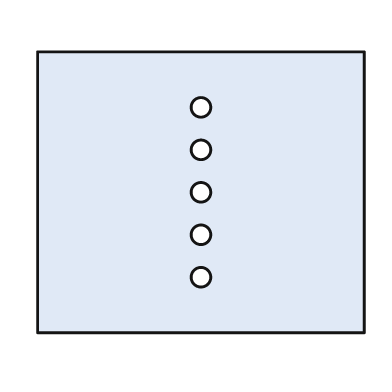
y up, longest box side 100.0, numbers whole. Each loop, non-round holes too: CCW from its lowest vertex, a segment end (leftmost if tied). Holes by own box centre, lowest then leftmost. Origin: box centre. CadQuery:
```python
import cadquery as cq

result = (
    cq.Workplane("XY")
    .moveTo(-50.0, -43.0)
    .lineTo(50.0, -43.0)
    .lineTo(50.0, 43.0)
    .lineTo(-50.0, 43.0)
    .close()
    .moveTo(0.0, -26.0)
    .circle(3.0)
    .moveTo(0.0, -13.0)
    .circle(3.0)
    .moveTo(0.0, 0.0)
    .circle(3.0)
    .moveTo(0.0, 13.0)
    .circle(3.0)
    .moveTo(0.0, 26.0)
    .circle(3.0)
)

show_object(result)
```